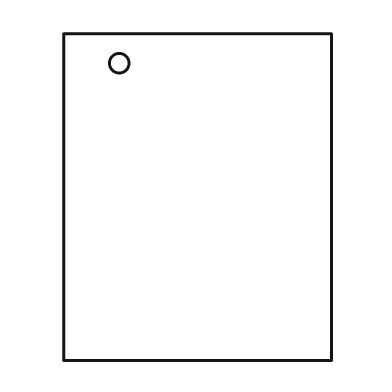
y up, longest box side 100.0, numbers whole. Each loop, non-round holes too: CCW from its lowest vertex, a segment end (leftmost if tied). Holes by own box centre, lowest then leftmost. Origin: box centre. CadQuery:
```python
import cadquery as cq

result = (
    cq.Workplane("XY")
    .moveTo(-41.0, -50.0)
    .lineTo(41.0, -50.0)
    .lineTo(41.0, 50.0)
    .lineTo(-41.0, 50.0)
    .close()
    .moveTo(-24.0, 41.0)
    .circle(3.0)
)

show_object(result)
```